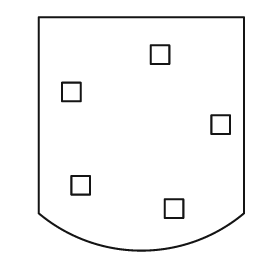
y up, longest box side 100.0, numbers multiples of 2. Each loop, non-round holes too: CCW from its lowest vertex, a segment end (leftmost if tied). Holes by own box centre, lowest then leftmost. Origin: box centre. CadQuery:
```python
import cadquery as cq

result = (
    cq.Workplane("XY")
    .moveTo(-44.0, -34.0)
    .threePointArc((0.0, -50.0), (44.0, -34.0))
    .lineTo(44.0, 50.0)
    .lineTo(-44.0, 50.0)
    .close()
    .moveTo(10.0, -36.0)
    .lineTo(18.0, -36.0)
    .lineTo(18.0, -28.0)
    .lineTo(10.0, -28.0)
    .close()
    .moveTo(-30.0, -26.0)
    .lineTo(-22.0, -26.0)
    .lineTo(-22.0, -18.0)
    .lineTo(-30.0, -18.0)
    .close()
    .moveTo(30.0, 0.0)
    .lineTo(38.0, 0.0)
    .lineTo(38.0, 8.0)
    .lineTo(30.0, 8.0)
    .close()
    .moveTo(-34.0, 14.0)
    .lineTo(-26.0, 14.0)
    .lineTo(-26.0, 22.0)
    .lineTo(-34.0, 22.0)
    .close()
    .moveTo(4.0, 30.0)
    .lineTo(12.0, 30.0)
    .lineTo(12.0, 38.0)
    .lineTo(4.0, 38.0)
    .close()
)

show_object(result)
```